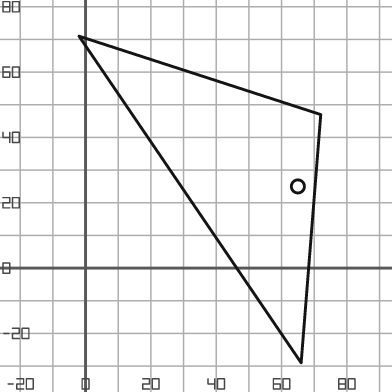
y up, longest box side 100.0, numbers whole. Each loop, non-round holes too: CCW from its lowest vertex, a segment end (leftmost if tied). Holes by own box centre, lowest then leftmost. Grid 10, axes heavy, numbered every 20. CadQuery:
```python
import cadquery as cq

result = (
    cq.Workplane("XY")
    .moveTo(66.0, -29.0)
    .lineTo(72.0, 47.0)
    .lineTo(-2.0, 71.0)
    .close()
    .moveTo(65.0, 25.0)
    .circle(2.0)
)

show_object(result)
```